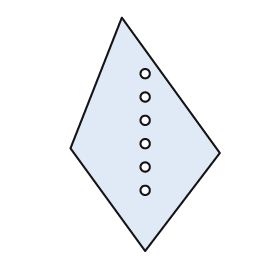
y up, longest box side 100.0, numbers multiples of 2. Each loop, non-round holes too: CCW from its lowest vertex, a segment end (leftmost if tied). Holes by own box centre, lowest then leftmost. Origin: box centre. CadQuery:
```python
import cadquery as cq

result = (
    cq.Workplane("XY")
    .moveTo(0.0, -50.0)
    .lineTo(32.0, -8.0)
    .lineTo(-10.0, 50.0)
    .lineTo(-32.0, -6.0)
    .close()
    .moveTo(0.0, -24.0)
    .circle(2.0)
    .moveTo(0.0, -14.0)
    .circle(2.0)
    .moveTo(0.0, -4.0)
    .circle(2.0)
    .moveTo(0.0, 6.0)
    .circle(2.0)
    .moveTo(0.0, 16.0)
    .circle(2.0)
    .moveTo(0.0, 26.0)
    .circle(2.0)
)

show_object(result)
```